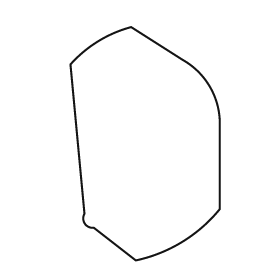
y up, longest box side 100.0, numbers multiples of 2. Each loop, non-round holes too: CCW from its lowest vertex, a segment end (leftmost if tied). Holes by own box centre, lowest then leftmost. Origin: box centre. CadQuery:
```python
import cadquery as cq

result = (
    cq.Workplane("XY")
    .moveTo(-4.0, -50.0)
    .threePointArc((16.0, -42.0), (32.0, -28.0))
    .lineTo(32.0, 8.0)
    .threePointArc((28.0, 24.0), (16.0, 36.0))
    .lineTo(-6.0, 50.0)
    .threePointArc((-20.0, 44.0), (-32.0, 34.0))
    .lineTo(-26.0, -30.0)
    .threePointArc((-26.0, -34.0), (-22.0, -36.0))
    .close()
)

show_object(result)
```